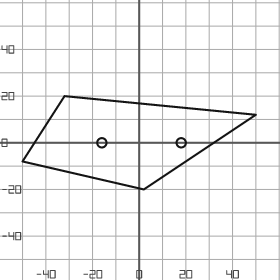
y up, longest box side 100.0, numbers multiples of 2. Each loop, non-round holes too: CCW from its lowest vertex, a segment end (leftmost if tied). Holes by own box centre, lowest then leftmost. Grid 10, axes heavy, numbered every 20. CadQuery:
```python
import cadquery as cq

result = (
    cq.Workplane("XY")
    .moveTo(2.0, -20.0)
    .lineTo(50.0, 12.0)
    .lineTo(-32.0, 20.0)
    .lineTo(-50.0, -8.0)
    .close()
    .moveTo(-16.0, 0.0)
    .circle(2.0)
    .moveTo(18.0, 0.0)
    .circle(2.0)
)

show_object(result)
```